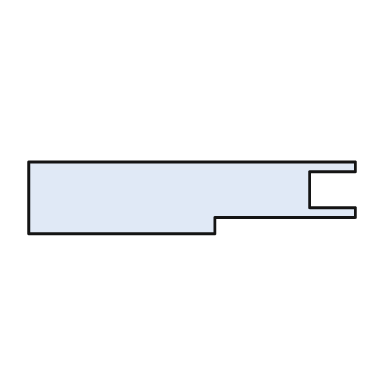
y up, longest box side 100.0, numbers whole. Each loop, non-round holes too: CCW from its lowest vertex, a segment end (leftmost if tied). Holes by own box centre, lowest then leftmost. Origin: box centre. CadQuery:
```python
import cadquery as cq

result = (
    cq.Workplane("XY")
    .moveTo(-50.0, -11.0)
    .lineTo(7.0, -11.0)
    .lineTo(7.0, -6.0)
    .lineTo(50.0, -6.0)
    .lineTo(50.0, -3.0)
    .lineTo(36.0, -3.0)
    .lineTo(36.0, 8.0)
    .lineTo(50.0, 8.0)
    .lineTo(50.0, 11.0)
    .lineTo(-50.0, 11.0)
    .close()
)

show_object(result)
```